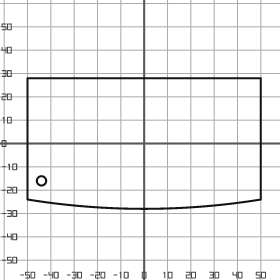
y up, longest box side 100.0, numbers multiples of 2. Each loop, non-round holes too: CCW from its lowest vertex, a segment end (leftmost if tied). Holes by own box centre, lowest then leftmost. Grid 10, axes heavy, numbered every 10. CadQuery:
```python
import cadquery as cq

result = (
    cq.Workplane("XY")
    .moveTo(-50.0, -24.0)
    .threePointArc((0.0, -28.0), (50.0, -24.0))
    .lineTo(50.0, 28.0)
    .lineTo(-50.0, 28.0)
    .close()
    .moveTo(-44.0, -16.0)
    .circle(2.0)
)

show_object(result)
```